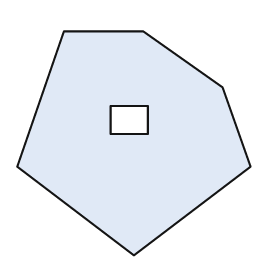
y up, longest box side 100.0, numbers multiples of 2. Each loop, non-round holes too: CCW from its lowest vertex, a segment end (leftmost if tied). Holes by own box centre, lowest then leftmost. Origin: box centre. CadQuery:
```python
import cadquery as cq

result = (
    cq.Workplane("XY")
    .moveTo(0.0, -48.0)
    .lineTo(50.0, -10.0)
    .lineTo(38.0, 24.0)
    .lineTo(4.0, 48.0)
    .lineTo(-30.0, 48.0)
    .lineTo(-50.0, -10.0)
    .close()
    .moveTo(-10.0, 4.0)
    .lineTo(6.0, 4.0)
    .lineTo(6.0, 16.0)
    .lineTo(-10.0, 16.0)
    .close()
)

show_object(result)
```